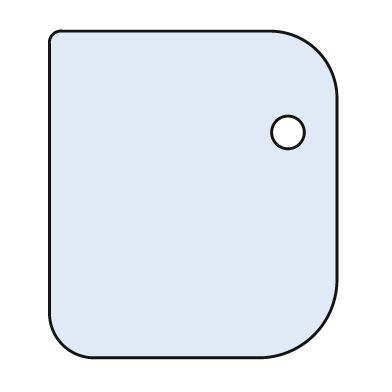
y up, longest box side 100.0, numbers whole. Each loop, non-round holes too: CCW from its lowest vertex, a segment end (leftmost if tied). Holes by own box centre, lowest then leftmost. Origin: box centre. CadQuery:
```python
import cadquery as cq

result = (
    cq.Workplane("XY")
    .moveTo(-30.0, -50.0)
    .lineTo(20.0, -50.0)
    .threePointArc((37.0, -43.0), (44.0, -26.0))
    .lineTo(44.0, 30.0)
    .threePointArc((38.0, 44.0), (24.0, 50.0))
    .lineTo(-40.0, 50.0)
    .threePointArc((-43.0, 49.0), (-44.0, 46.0))
    .lineTo(-44.0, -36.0)
    .threePointArc((-40.0, -46.0), (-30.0, -50.0))
    .close()
    .moveTo(29.0, 19.0)
    .circle(5.0)
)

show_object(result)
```